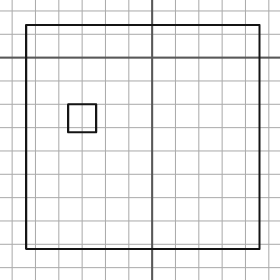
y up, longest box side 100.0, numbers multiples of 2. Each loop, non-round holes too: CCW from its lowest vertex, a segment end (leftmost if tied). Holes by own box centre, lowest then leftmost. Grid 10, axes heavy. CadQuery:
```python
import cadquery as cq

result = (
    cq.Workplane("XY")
    .moveTo(-54.0, -82.0)
    .lineTo(46.0, -82.0)
    .lineTo(46.0, 14.0)
    .lineTo(-54.0, 14.0)
    .close()
    .moveTo(-36.0, -32.0)
    .lineTo(-24.0, -32.0)
    .lineTo(-24.0, -20.0)
    .lineTo(-36.0, -20.0)
    .close()
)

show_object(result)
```